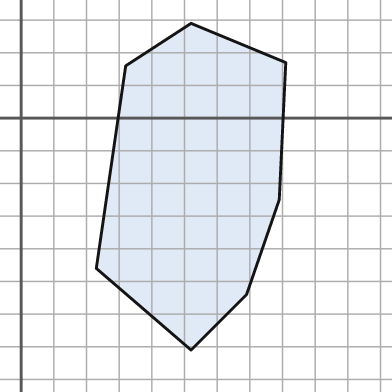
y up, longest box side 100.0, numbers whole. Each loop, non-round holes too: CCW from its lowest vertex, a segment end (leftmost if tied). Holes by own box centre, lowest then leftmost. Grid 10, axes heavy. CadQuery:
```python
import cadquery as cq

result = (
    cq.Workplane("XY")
    .moveTo(52.0, -71.0)
    .lineTo(69.0, -54.0)
    .lineTo(79.0, -25.0)
    .lineTo(81.0, 17.0)
    .lineTo(52.0, 29.0)
    .lineTo(32.0, 16.0)
    .lineTo(23.0, -46.0)
    .close()
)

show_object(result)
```